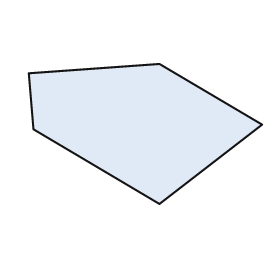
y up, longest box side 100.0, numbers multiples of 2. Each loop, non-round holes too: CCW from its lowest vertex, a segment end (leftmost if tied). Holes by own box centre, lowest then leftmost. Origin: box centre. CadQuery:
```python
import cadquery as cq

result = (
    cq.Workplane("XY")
    .moveTo(6.0, -30.0)
    .lineTo(50.0, 4.0)
    .lineTo(6.0, 30.0)
    .lineTo(-50.0, 26.0)
    .lineTo(-48.0, 2.0)
    .close()
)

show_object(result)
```